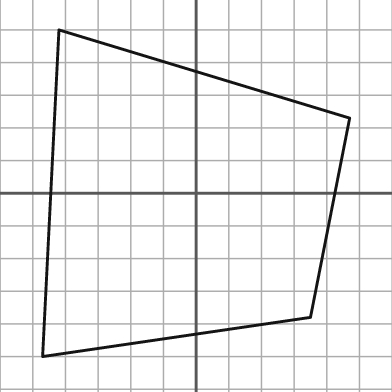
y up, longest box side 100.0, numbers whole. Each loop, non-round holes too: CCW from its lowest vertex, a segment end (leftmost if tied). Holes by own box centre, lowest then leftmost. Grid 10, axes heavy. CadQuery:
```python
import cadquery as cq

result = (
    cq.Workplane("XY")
    .moveTo(-47.0, -50.0)
    .lineTo(35.0, -38.0)
    .lineTo(47.0, 23.0)
    .lineTo(-42.0, 50.0)
    .close()
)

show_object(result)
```